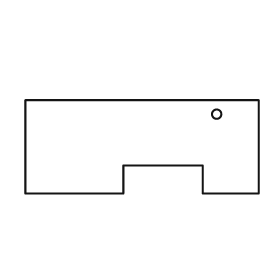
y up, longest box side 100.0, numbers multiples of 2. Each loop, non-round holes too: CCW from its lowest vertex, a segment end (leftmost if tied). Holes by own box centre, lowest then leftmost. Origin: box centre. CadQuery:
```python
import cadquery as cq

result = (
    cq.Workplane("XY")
    .moveTo(-50.0, -20.0)
    .lineTo(-8.0, -20.0)
    .lineTo(-8.0, -8.0)
    .lineTo(26.0, -8.0)
    .lineTo(26.0, -20.0)
    .lineTo(50.0, -20.0)
    .lineTo(50.0, 20.0)
    .lineTo(-50.0, 20.0)
    .close()
    .moveTo(32.0, 14.0)
    .circle(2.0)
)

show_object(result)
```